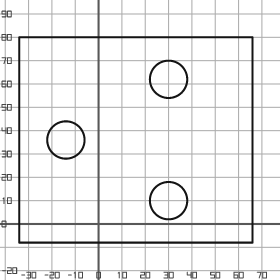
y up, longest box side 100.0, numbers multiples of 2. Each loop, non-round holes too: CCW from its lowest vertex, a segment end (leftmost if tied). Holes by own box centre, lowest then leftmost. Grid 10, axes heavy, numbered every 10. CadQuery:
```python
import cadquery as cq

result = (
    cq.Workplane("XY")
    .moveTo(-34.0, -8.0)
    .lineTo(66.0, -8.0)
    .lineTo(66.0, 80.0)
    .lineTo(-34.0, 80.0)
    .close()
    .moveTo(30.0, 10.0)
    .circle(8.0)
    .moveTo(-14.0, 36.0)
    .circle(8.0)
    .moveTo(30.0, 62.0)
    .circle(8.0)
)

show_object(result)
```